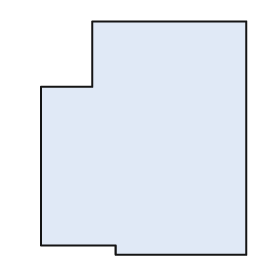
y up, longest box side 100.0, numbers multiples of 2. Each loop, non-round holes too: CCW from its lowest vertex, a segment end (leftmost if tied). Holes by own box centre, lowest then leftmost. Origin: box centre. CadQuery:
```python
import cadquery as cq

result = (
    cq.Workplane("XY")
    .moveTo(-12.0, -50.0)
    .lineTo(44.0, -50.0)
    .lineTo(44.0, 50.0)
    .lineTo(-22.0, 50.0)
    .lineTo(-22.0, 22.0)
    .lineTo(-44.0, 22.0)
    .lineTo(-44.0, -46.0)
    .lineTo(-12.0, -46.0)
    .close()
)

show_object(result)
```